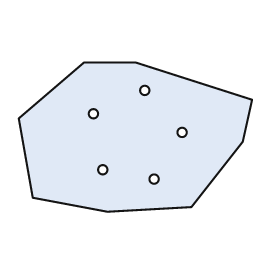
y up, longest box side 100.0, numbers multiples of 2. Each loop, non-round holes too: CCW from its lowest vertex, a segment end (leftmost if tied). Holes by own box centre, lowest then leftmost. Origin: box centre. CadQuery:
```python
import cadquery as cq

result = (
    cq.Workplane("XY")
    .moveTo(-12.0, -32.0)
    .lineTo(24.0, -30.0)
    .lineTo(46.0, -2.0)
    .lineTo(50.0, 16.0)
    .lineTo(0.0, 32.0)
    .lineTo(-22.0, 32.0)
    .lineTo(-50.0, 8.0)
    .lineTo(-44.0, -26.0)
    .close()
    .moveTo(8.0, -18.0)
    .circle(2.0)
    .moveTo(-14.0, -14.0)
    .circle(2.0)
    .moveTo(20.0, 2.0)
    .circle(2.0)
    .moveTo(-18.0, 10.0)
    .circle(2.0)
    .moveTo(4.0, 20.0)
    .circle(2.0)
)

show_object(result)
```